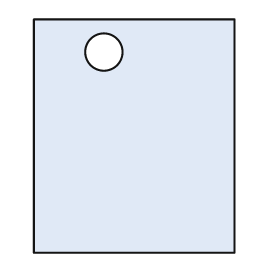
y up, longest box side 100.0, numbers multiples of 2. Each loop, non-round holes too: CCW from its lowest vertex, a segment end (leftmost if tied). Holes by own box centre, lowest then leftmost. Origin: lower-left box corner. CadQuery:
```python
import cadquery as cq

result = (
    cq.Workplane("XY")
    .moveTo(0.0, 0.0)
    .lineTo(86.0, 0.0)
    .lineTo(86.0, 100.0)
    .lineTo(0.0, 100.0)
    .close()
    .moveTo(30.0, 86.0)
    .circle(8.0)
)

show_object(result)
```